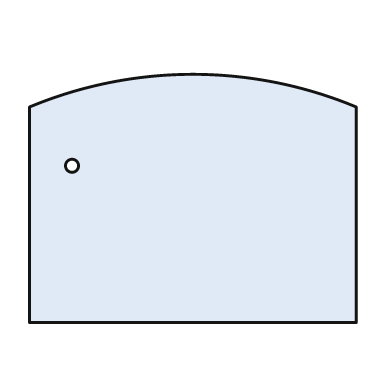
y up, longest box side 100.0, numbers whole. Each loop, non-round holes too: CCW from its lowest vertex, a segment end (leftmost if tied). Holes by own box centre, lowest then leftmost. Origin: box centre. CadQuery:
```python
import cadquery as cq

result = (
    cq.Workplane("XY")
    .moveTo(-50.0, -38.0)
    .lineTo(50.0, -38.0)
    .lineTo(50.0, 28.0)
    .threePointArc((0.0, 38.0), (-50.0, 28.0))
    .close()
    .moveTo(-37.0, 10.0)
    .circle(2.0)
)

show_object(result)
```